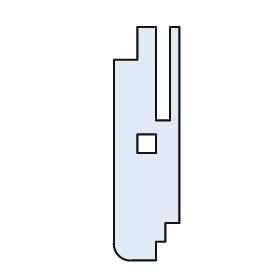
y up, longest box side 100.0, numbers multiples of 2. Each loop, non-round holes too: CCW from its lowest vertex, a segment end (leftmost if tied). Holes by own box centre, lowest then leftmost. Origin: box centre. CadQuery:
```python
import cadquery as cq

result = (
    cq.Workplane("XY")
    .moveTo(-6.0, -50.0)
    .lineTo(4.0, -50.0)
    .lineTo(4.0, -42.0)
    .lineTo(8.0, -42.0)
    .lineTo(8.0, -34.0)
    .lineTo(14.0, -34.0)
    .lineTo(14.0, 50.0)
    .lineTo(10.0, 50.0)
    .lineTo(10.0, 10.0)
    .lineTo(4.0, 10.0)
    .lineTo(4.0, 50.0)
    .lineTo(-4.0, 50.0)
    .lineTo(-4.0, 36.0)
    .lineTo(-14.0, 36.0)
    .lineTo(-14.0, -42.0)
    .threePointArc((-12.0, -48.0), (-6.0, -50.0))
    .close()
    .moveTo(-4.0, -4.0)
    .lineTo(4.0, -4.0)
    .lineTo(4.0, 4.0)
    .lineTo(-4.0, 4.0)
    .close()
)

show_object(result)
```